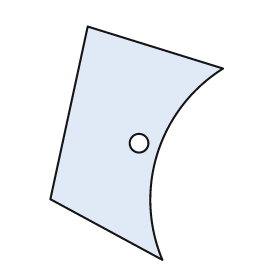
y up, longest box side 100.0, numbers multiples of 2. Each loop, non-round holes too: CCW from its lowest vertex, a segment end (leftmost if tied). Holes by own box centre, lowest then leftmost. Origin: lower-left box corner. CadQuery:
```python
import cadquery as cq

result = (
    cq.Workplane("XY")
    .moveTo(48.0, 0.0)
    .threePointArc((46.0, 46.0), (74.0, 82.0))
    .lineTo(16.0, 100.0)
    .lineTo(0.0, 26.0)
    .close()
    .moveTo(38.0, 50.0)
    .circle(4.0)
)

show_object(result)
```